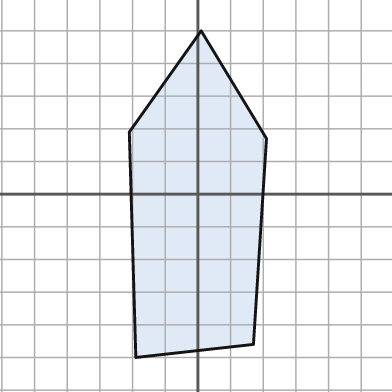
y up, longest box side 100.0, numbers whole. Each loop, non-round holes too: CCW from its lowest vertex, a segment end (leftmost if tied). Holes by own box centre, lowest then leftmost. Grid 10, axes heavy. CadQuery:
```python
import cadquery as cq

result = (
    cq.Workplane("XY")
    .moveTo(-19.0, -50.0)
    .lineTo(17.0, -46.0)
    .lineTo(21.0, 17.0)
    .lineTo(1.0, 50.0)
    .lineTo(-21.0, 19.0)
    .close()
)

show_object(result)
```